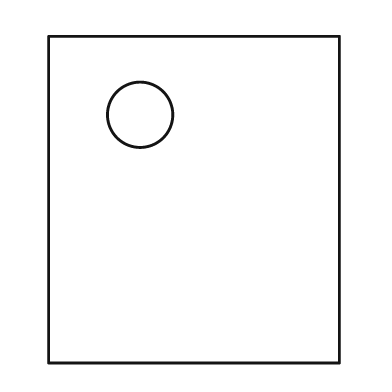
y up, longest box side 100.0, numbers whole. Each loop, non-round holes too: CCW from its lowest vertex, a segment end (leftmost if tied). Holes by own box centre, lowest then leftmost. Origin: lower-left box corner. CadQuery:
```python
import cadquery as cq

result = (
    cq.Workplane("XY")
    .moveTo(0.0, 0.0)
    .lineTo(89.0, 0.0)
    .lineTo(89.0, 100.0)
    .lineTo(0.0, 100.0)
    .close()
    .moveTo(28.0, 76.0)
    .circle(10.0)
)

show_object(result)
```